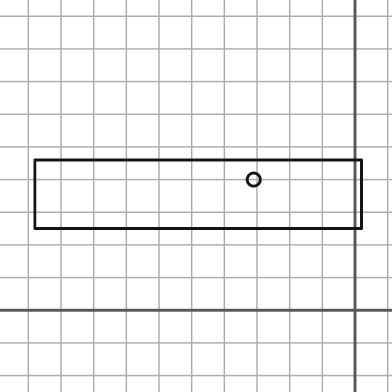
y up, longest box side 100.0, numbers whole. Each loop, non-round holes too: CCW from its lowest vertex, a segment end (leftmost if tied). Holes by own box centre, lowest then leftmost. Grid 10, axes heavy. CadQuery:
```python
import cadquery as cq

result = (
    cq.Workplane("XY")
    .moveTo(-98.0, 25.0)
    .lineTo(2.0, 25.0)
    .lineTo(2.0, 46.0)
    .lineTo(-98.0, 46.0)
    .close()
    .moveTo(-31.0, 40.0)
    .circle(2.0)
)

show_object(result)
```